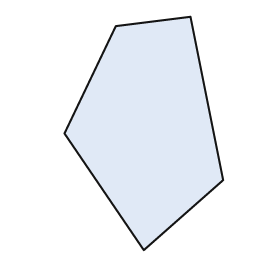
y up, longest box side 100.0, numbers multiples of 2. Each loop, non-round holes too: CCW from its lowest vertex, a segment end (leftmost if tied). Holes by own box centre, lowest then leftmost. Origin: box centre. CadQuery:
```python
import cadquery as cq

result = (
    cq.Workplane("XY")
    .moveTo(0.0, -50.0)
    .lineTo(34.0, -20.0)
    .lineTo(20.0, 50.0)
    .lineTo(-12.0, 46.0)
    .lineTo(-34.0, 0.0)
    .close()
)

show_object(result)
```